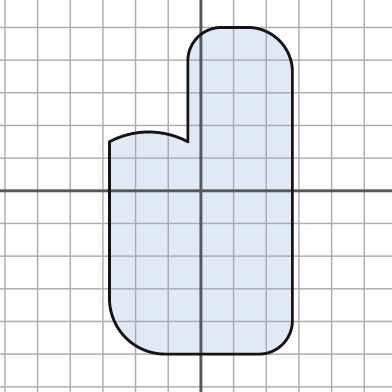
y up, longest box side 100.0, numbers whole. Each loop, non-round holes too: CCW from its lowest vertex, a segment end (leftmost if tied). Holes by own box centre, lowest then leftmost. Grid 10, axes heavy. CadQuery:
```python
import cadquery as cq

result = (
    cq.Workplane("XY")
    .moveTo(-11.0, -50.0)
    .lineTo(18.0, -50.0)
    .threePointArc((25.0, -47.0), (28.0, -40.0))
    .lineTo(28.0, 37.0)
    .threePointArc((24.0, 46.0), (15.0, 50.0))
    .lineTo(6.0, 50.0)
    .threePointArc((-1.0, 47.0), (-4.0, 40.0))
    .lineTo(-4.0, 15.0)
    .threePointArc((-16.0, 18.0), (-28.0, 15.0))
    .lineTo(-28.0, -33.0)
    .threePointArc((-23.0, -45.0), (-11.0, -50.0))
    .close()
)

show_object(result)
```